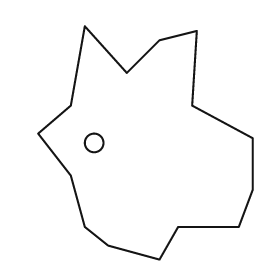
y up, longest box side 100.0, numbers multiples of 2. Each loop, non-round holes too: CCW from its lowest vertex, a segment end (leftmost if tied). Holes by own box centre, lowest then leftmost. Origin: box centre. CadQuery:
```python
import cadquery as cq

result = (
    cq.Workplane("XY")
    .moveTo(6.0, -50.0)
    .lineTo(14.0, -36.0)
    .lineTo(40.0, -36.0)
    .lineTo(46.0, -20.0)
    .lineTo(46.0, 2.0)
    .lineTo(20.0, 16.0)
    .lineTo(22.0, 48.0)
    .lineTo(6.0, 44.0)
    .lineTo(-8.0, 30.0)
    .lineTo(-26.0, 50.0)
    .lineTo(-32.0, 16.0)
    .lineTo(-46.0, 4.0)
    .lineTo(-32.0, -14.0)
    .lineTo(-26.0, -36.0)
    .lineTo(-16.0, -44.0)
    .close()
    .moveTo(-22.0, 0.0)
    .circle(4.0)
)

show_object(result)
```